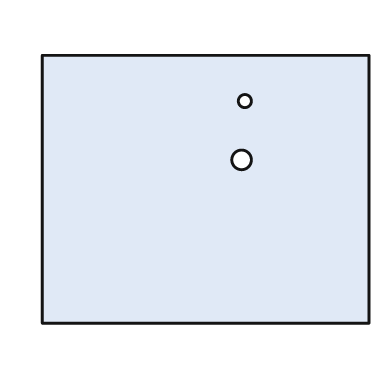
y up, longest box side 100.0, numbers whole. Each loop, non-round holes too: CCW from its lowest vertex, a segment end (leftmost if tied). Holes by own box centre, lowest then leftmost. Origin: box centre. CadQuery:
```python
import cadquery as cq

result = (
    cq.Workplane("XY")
    .moveTo(-50.0, -41.0)
    .lineTo(50.0, -41.0)
    .lineTo(50.0, 41.0)
    .lineTo(-50.0, 41.0)
    .close()
    .moveTo(11.0, 9.0)
    .circle(3.0)
    .moveTo(12.0, 27.0)
    .circle(2.0)
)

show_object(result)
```